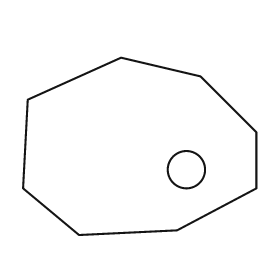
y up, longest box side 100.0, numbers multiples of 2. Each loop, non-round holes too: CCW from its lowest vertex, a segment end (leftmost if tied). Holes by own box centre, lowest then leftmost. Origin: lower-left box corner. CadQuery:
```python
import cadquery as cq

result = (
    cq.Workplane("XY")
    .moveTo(24.0, 0.0)
    .lineTo(66.0, 2.0)
    .lineTo(100.0, 20.0)
    .lineTo(100.0, 44.0)
    .lineTo(76.0, 68.0)
    .lineTo(42.0, 76.0)
    .lineTo(2.0, 58.0)
    .lineTo(0.0, 20.0)
    .close()
    .moveTo(70.0, 28.0)
    .circle(8.0)
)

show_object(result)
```